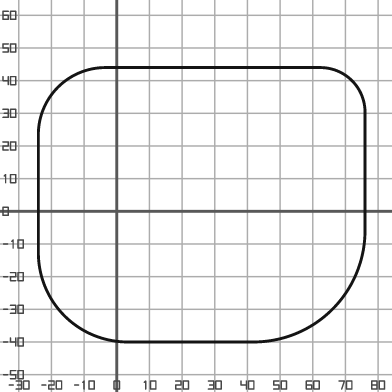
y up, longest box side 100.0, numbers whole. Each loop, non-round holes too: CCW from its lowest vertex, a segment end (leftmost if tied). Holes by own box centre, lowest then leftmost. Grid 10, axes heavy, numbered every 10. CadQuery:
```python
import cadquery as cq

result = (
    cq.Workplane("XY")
    .moveTo(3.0, -40.0)
    .lineTo(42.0, -40.0)
    .threePointArc((66.0, -30.0), (76.0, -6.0))
    .lineTo(76.0, 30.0)
    .threePointArc((72.0, 40.0), (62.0, 44.0))
    .lineTo(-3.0, 44.0)
    .threePointArc((-18.0, 38.0), (-24.0, 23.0))
    .lineTo(-24.0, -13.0)
    .threePointArc((-16.0, -32.0), (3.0, -40.0))
    .close()
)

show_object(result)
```